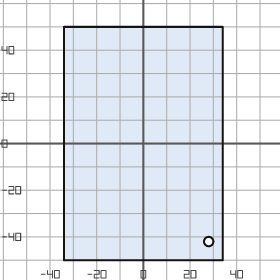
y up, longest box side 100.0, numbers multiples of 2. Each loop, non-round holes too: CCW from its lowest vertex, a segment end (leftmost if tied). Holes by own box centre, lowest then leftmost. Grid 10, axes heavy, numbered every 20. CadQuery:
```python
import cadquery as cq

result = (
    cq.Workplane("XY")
    .moveTo(-34.0, -50.0)
    .lineTo(34.0, -50.0)
    .lineTo(34.0, 50.0)
    .lineTo(-34.0, 50.0)
    .close()
    .moveTo(28.0, -42.0)
    .circle(2.0)
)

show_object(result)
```